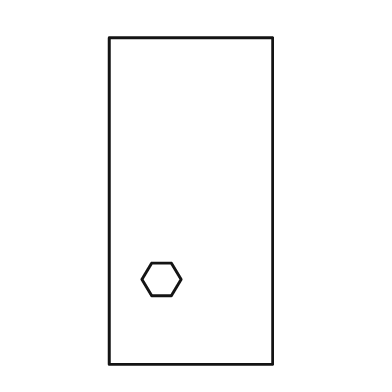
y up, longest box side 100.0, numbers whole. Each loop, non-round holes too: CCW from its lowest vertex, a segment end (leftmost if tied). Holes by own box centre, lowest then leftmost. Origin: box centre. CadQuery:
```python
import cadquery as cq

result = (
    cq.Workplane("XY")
    .moveTo(-25.0, -50.0)
    .lineTo(25.0, -50.0)
    .lineTo(25.0, 50.0)
    .lineTo(-25.0, 50.0)
    .close()
    .moveTo(-12.0, -29.0)
    .lineTo(-6.0, -29.0)
    .lineTo(-3.0, -24.0)
    .lineTo(-6.0, -19.0)
    .lineTo(-12.0, -19.0)
    .lineTo(-15.0, -24.0)
    .close()
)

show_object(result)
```